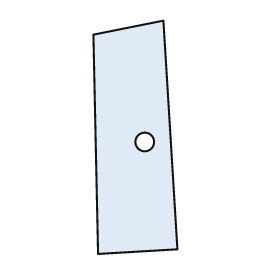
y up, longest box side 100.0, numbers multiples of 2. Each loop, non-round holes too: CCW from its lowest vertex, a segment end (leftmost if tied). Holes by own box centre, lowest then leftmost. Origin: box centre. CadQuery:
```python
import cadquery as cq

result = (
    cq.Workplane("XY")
    .moveTo(-16.0, -50.0)
    .lineTo(18.0, -48.0)
    .lineTo(12.0, 50.0)
    .lineTo(-18.0, 44.0)
    .close()
    .moveTo(4.0, -2.0)
    .circle(4.0)
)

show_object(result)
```